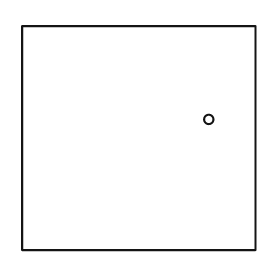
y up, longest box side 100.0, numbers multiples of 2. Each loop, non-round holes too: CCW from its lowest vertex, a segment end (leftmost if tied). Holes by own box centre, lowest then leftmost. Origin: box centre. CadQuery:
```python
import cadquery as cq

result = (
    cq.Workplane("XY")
    .moveTo(-50.0, -48.0)
    .lineTo(50.0, -48.0)
    .lineTo(50.0, 48.0)
    .lineTo(-50.0, 48.0)
    .close()
    .moveTo(30.0, 8.0)
    .circle(2.0)
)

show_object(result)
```